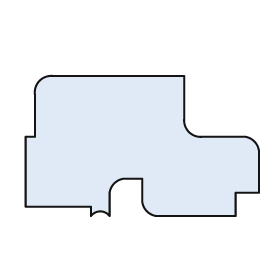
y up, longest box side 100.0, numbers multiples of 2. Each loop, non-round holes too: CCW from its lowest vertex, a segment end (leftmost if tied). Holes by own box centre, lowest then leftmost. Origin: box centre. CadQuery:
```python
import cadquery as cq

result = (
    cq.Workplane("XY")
    .moveTo(-22.0, -30.0)
    .threePointArc((-18.0, -28.0), (-14.0, -30.0))
    .lineTo(-14.0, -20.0)
    .threePointArc((-12.0, -16.0), (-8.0, -14.0))
    .lineTo(0.0, -14.0)
    .lineTo(0.0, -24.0)
    .threePointArc((2.0, -28.0), (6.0, -30.0))
    .lineTo(40.0, -30.0)
    .lineTo(40.0, -20.0)
    .lineTo(50.0, -20.0)
    .lineTo(50.0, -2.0)
    .threePointArc((48.0, 2.0), (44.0, 4.0))
    .lineTo(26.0, 4.0)
    .threePointArc((20.0, 6.0), (18.0, 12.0))
    .lineTo(18.0, 30.0)
    .lineTo(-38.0, 30.0)
    .threePointArc((-44.0, 28.0), (-46.0, 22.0))
    .lineTo(-46.0, 4.0)
    .lineTo(-50.0, 4.0)
    .lineTo(-50.0, -26.0)
    .lineTo(-22.0, -26.0)
    .close()
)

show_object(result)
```